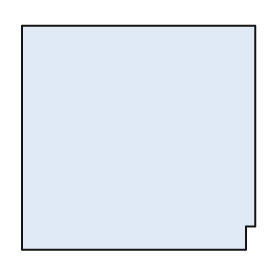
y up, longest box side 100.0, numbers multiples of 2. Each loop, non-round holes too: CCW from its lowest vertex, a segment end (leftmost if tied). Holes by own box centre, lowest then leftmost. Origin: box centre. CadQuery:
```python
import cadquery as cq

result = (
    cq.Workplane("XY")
    .moveTo(-50.0, -48.0)
    .lineTo(46.0, -48.0)
    .lineTo(46.0, -38.0)
    .lineTo(50.0, -38.0)
    .lineTo(50.0, 48.0)
    .lineTo(-50.0, 48.0)
    .close()
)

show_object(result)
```